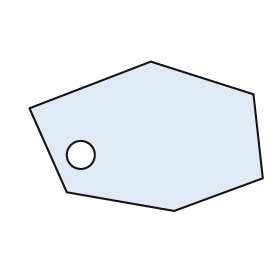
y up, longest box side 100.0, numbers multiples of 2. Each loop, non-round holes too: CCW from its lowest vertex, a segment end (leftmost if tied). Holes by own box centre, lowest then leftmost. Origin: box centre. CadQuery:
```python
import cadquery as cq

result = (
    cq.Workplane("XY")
    .moveTo(12.0, -32.0)
    .lineTo(50.0, -18.0)
    .lineTo(46.0, 18.0)
    .lineTo(2.0, 32.0)
    .lineTo(-50.0, 12.0)
    .lineTo(-34.0, -24.0)
    .close()
    .moveTo(-28.0, -8.0)
    .circle(6.0)
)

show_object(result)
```